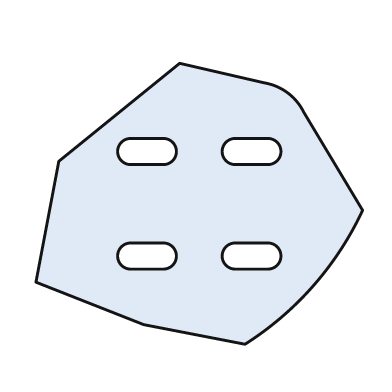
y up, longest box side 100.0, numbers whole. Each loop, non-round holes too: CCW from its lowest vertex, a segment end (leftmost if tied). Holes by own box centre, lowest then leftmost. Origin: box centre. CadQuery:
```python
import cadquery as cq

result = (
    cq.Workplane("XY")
    .moveTo(14.0, -43.0)
    .threePointArc((35.0, -25.0), (50.0, -2.0))
    .lineTo(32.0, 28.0)
    .threePointArc((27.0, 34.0), (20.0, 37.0))
    .lineTo(-6.0, 43.0)
    .lineTo(-43.0, 13.0)
    .lineTo(-50.0, -24.0)
    .lineTo(-17.0, -37.0)
    .close()
    .moveTo(-21.0, -20.0)
    .lineTo(-11.0, -20.0)
    .threePointArc((-7.0, -16.0), (-11.0, -12.0))
    .lineTo(-21.0, -12.0)
    .threePointArc((-25.0, -16.0), (-21.0, -20.0))
    .close()
    .moveTo(11.0, -20.0)
    .lineTo(21.0, -20.0)
    .threePointArc((25.0, -16.0), (21.0, -12.0))
    .lineTo(11.0, -12.0)
    .threePointArc((7.0, -16.0), (11.0, -20.0))
    .close()
    .moveTo(-21.0, 12.0)
    .lineTo(-11.0, 12.0)
    .threePointArc((-7.0, 16.0), (-11.0, 20.0))
    .lineTo(-21.0, 20.0)
    .threePointArc((-25.0, 16.0), (-21.0, 12.0))
    .close()
    .moveTo(11.0, 12.0)
    .lineTo(21.0, 12.0)
    .threePointArc((25.0, 16.0), (21.0, 20.0))
    .lineTo(11.0, 20.0)
    .threePointArc((7.0, 16.0), (11.0, 12.0))
    .close()
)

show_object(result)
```